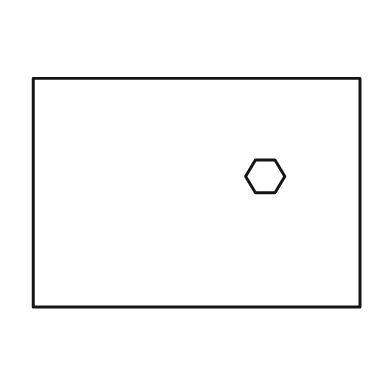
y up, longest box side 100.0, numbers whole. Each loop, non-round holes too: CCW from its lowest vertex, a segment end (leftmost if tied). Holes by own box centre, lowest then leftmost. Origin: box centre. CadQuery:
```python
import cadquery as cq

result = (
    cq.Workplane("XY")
    .moveTo(-50.0, -35.0)
    .lineTo(50.0, -35.0)
    .lineTo(50.0, 35.0)
    .lineTo(-50.0, 35.0)
    .close()
    .moveTo(18.0, 0.0)
    .lineTo(24.0, 0.0)
    .lineTo(27.0, 5.0)
    .lineTo(24.0, 10.0)
    .lineTo(18.0, 10.0)
    .lineTo(15.0, 5.0)
    .close()
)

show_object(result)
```